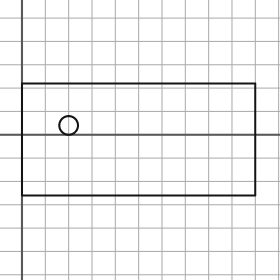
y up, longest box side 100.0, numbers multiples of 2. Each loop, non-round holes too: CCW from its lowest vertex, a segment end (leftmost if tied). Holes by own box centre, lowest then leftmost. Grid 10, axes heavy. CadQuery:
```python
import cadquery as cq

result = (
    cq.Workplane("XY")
    .moveTo(0.0, -26.0)
    .lineTo(100.0, -26.0)
    .lineTo(100.0, 22.0)
    .lineTo(0.0, 22.0)
    .close()
    .moveTo(20.0, 4.0)
    .circle(4.0)
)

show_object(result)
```